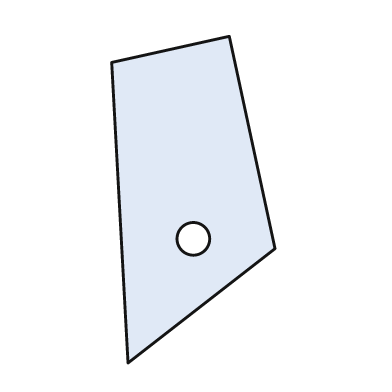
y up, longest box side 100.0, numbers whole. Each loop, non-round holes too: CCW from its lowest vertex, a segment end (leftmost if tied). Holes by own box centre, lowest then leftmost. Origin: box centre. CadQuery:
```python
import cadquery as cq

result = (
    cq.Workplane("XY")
    .moveTo(-20.0, -50.0)
    .lineTo(25.0, -15.0)
    .lineTo(11.0, 50.0)
    .lineTo(-25.0, 42.0)
    .close()
    .moveTo(0.0, -12.0)
    .circle(5.0)
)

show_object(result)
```